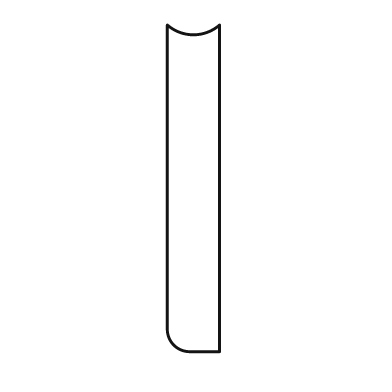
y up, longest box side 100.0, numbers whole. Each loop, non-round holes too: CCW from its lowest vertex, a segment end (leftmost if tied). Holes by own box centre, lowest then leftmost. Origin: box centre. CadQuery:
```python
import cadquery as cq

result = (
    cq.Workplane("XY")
    .moveTo(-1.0, -50.0)
    .lineTo(8.0, -50.0)
    .lineTo(8.0, 50.0)
    .threePointArc((0.0, 47.0), (-8.0, 50.0))
    .lineTo(-8.0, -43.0)
    .threePointArc((-6.0, -48.0), (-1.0, -50.0))
    .close()
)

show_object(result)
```